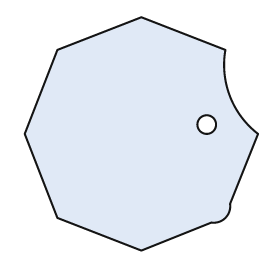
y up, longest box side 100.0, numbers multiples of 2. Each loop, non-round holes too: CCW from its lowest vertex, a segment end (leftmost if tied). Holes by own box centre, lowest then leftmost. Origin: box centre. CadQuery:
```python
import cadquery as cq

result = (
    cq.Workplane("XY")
    .moveTo(0.0, -50.0)
    .lineTo(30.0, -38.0)
    .threePointArc((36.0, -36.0), (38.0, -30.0))
    .lineTo(50.0, 0.0)
    .threePointArc((38.0, 16.0), (36.0, 36.0))
    .lineTo(0.0, 50.0)
    .lineTo(-36.0, 36.0)
    .lineTo(-50.0, 0.0)
    .lineTo(-36.0, -36.0)
    .close()
    .moveTo(28.0, 4.0)
    .circle(4.0)
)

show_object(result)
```